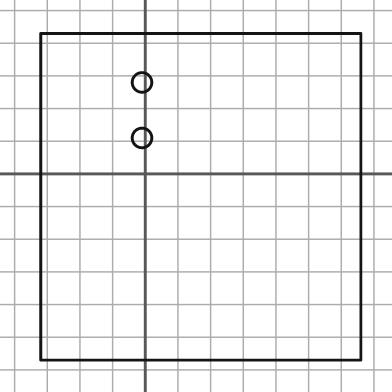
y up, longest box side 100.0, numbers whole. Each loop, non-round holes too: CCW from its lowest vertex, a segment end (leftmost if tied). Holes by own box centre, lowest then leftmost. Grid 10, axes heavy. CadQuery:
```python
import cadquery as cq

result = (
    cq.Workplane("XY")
    .moveTo(-32.0, -57.0)
    .lineTo(66.0, -57.0)
    .lineTo(66.0, 43.0)
    .lineTo(-32.0, 43.0)
    .close()
    .moveTo(-1.0, 11.0)
    .circle(3.0)
    .moveTo(-1.0, 28.0)
    .circle(3.0)
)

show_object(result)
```